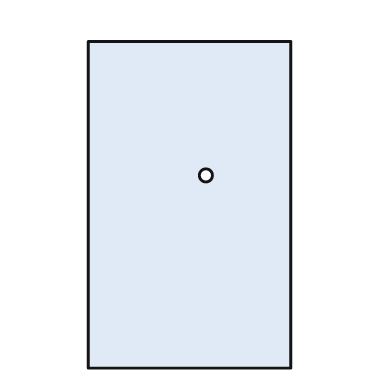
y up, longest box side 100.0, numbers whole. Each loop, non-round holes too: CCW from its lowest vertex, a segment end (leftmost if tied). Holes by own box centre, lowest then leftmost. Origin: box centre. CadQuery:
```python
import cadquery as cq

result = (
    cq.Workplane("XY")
    .moveTo(-31.0, -50.0)
    .lineTo(31.0, -50.0)
    .lineTo(31.0, 50.0)
    .lineTo(-31.0, 50.0)
    .close()
    .moveTo(5.0, 9.0)
    .circle(2.0)
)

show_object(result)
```